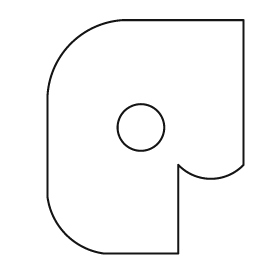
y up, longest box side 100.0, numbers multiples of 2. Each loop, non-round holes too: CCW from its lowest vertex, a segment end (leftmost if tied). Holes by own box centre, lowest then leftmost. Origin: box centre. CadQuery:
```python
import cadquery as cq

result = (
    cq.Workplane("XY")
    .moveTo(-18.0, -50.0)
    .lineTo(14.0, -50.0)
    .lineTo(14.0, -12.0)
    .threePointArc((28.0, -18.0), (42.0, -12.0))
    .lineTo(42.0, 50.0)
    .lineTo(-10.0, 50.0)
    .threePointArc((-32.0, 40.0), (-42.0, 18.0))
    .lineTo(-42.0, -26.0)
    .threePointArc((-34.0, -42.0), (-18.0, -50.0))
    .close()
    .moveTo(-2.0, 4.0)
    .circle(10.0)
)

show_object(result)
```